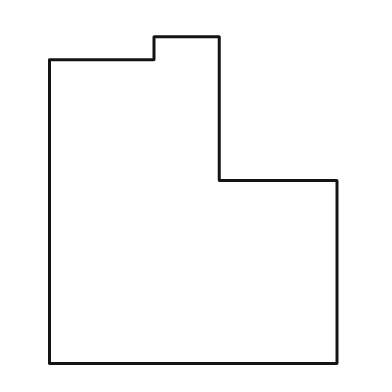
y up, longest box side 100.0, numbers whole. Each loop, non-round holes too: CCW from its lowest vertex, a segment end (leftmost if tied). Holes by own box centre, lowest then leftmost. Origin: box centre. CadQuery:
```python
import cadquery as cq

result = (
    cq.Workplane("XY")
    .moveTo(-44.0, -50.0)
    .lineTo(44.0, -50.0)
    .lineTo(44.0, 6.0)
    .lineTo(8.0, 6.0)
    .lineTo(8.0, 50.0)
    .lineTo(-12.0, 50.0)
    .lineTo(-12.0, 43.0)
    .lineTo(-44.0, 43.0)
    .close()
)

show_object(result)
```